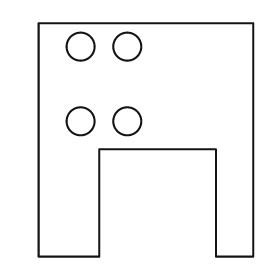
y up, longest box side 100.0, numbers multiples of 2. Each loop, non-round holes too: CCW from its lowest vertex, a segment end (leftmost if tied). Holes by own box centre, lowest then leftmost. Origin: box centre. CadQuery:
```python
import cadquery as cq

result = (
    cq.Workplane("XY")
    .moveTo(-46.0, -50.0)
    .lineTo(-20.0, -50.0)
    .lineTo(-20.0, -4.0)
    .lineTo(30.0, -4.0)
    .lineTo(30.0, -50.0)
    .lineTo(46.0, -50.0)
    .lineTo(46.0, 50.0)
    .lineTo(-46.0, 50.0)
    .close()
    .moveTo(-28.0, 8.0)
    .circle(6.0)
    .moveTo(-8.0, 8.0)
    .circle(6.0)
    .moveTo(-28.0, 40.0)
    .circle(6.0)
    .moveTo(-8.0, 40.0)
    .circle(6.0)
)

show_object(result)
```